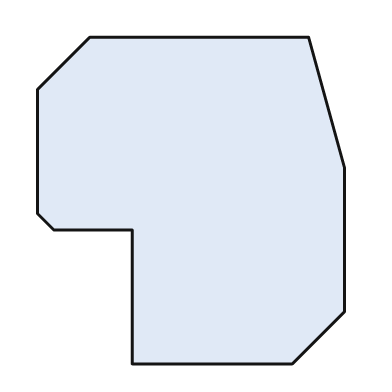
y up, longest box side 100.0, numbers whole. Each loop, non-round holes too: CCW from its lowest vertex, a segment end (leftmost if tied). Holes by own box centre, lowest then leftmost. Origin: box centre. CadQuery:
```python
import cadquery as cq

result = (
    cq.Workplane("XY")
    .moveTo(-18.0, -50.0)
    .lineTo(31.0, -50.0)
    .lineTo(47.0, -34.0)
    .lineTo(47.0, 10.0)
    .lineTo(36.0, 50.0)
    .lineTo(-31.0, 50.0)
    .lineTo(-47.0, 34.0)
    .lineTo(-47.0, -4.0)
    .lineTo(-42.0, -9.0)
    .lineTo(-18.0, -9.0)
    .close()
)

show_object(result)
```